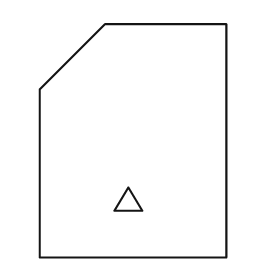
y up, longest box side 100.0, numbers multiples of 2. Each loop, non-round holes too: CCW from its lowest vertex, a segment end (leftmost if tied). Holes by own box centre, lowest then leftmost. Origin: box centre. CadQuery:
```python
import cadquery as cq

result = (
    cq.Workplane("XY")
    .moveTo(-40.0, -50.0)
    .lineTo(40.0, -50.0)
    .lineTo(40.0, 50.0)
    .lineTo(-12.0, 50.0)
    .lineTo(-40.0, 22.0)
    .close()
    .moveTo(-8.0, -30.0)
    .lineTo(4.0, -30.0)
    .lineTo(-2.0, -20.0)
    .close()
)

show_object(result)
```